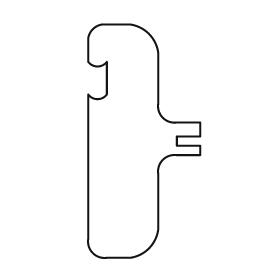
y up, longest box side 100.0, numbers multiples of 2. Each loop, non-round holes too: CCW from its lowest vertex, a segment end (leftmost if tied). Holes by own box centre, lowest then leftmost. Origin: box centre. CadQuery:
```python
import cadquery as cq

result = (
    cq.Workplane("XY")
    .moveTo(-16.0, -50.0)
    .lineTo(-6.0, -50.0)
    .threePointArc((2.0, -46.0), (6.0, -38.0))
    .lineTo(6.0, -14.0)
    .threePointArc((8.0, -8.0), (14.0, -6.0))
    .lineTo(24.0, -6.0)
    .lineTo(24.0, -2.0)
    .lineTo(14.0, -2.0)
    .lineTo(14.0, 2.0)
    .lineTo(24.0, 2.0)
    .lineTo(24.0, 8.0)
    .lineTo(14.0, 8.0)
    .threePointArc((8.0, 10.0), (6.0, 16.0))
    .lineTo(6.0, 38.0)
    .threePointArc((2.0, 46.0), (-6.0, 50.0))
    .lineTo(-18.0, 50.0)
    .threePointArc((-22.0, 48.0), (-24.0, 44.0))
    .lineTo(-24.0, 34.0)
    .threePointArc((-20.0, 32.0), (-16.0, 34.0))
    .lineTo(-16.0, 20.0)
    .threePointArc((-20.0, 18.0), (-24.0, 20.0))
    .lineTo(-24.0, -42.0)
    .threePointArc((-22.0, -48.0), (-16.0, -50.0))
    .close()
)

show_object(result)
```